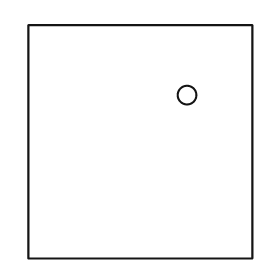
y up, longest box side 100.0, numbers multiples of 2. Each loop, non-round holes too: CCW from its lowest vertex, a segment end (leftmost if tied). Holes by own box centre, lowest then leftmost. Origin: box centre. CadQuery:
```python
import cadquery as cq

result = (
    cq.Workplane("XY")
    .moveTo(-48.0, -50.0)
    .lineTo(48.0, -50.0)
    .lineTo(48.0, 50.0)
    .lineTo(-48.0, 50.0)
    .close()
    .moveTo(20.0, 20.0)
    .circle(4.0)
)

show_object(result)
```